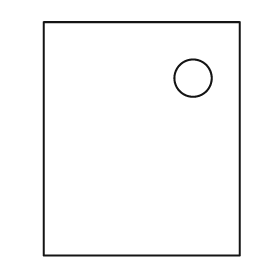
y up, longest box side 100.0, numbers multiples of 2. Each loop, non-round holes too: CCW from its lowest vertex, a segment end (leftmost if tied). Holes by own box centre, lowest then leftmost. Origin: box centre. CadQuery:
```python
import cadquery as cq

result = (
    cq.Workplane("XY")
    .moveTo(-42.0, -50.0)
    .lineTo(42.0, -50.0)
    .lineTo(42.0, 50.0)
    .lineTo(-42.0, 50.0)
    .close()
    .moveTo(22.0, 26.0)
    .circle(8.0)
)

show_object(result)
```